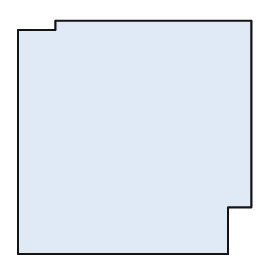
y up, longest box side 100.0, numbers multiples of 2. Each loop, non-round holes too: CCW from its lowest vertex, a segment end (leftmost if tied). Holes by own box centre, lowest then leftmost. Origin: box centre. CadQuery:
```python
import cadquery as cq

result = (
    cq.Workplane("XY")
    .moveTo(-50.0, -50.0)
    .lineTo(40.0, -50.0)
    .lineTo(40.0, -30.0)
    .lineTo(50.0, -30.0)
    .lineTo(50.0, 50.0)
    .lineTo(-34.0, 50.0)
    .lineTo(-34.0, 46.0)
    .lineTo(-50.0, 46.0)
    .close()
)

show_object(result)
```